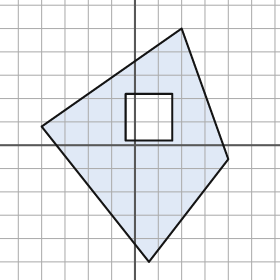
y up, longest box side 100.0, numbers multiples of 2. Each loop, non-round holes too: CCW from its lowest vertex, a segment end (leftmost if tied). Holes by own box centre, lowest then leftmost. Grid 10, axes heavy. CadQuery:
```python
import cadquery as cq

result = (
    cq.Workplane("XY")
    .moveTo(6.0, -50.0)
    .lineTo(40.0, -6.0)
    .lineTo(20.0, 50.0)
    .lineTo(-40.0, 8.0)
    .close()
    .moveTo(-4.0, 2.0)
    .lineTo(16.0, 2.0)
    .lineTo(16.0, 22.0)
    .lineTo(-4.0, 22.0)
    .close()
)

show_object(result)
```